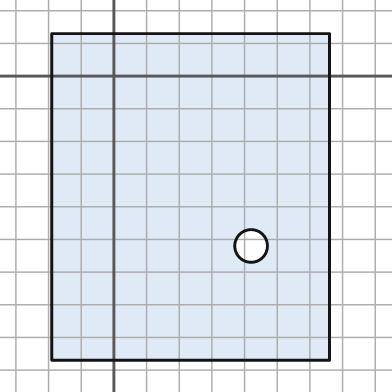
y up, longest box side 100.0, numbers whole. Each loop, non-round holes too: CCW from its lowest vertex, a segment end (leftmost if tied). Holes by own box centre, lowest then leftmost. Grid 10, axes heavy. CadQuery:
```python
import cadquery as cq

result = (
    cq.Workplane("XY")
    .moveTo(-19.0, -87.0)
    .lineTo(66.0, -87.0)
    .lineTo(66.0, 13.0)
    .lineTo(-19.0, 13.0)
    .close()
    .moveTo(42.0, -52.0)
    .circle(5.0)
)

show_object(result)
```